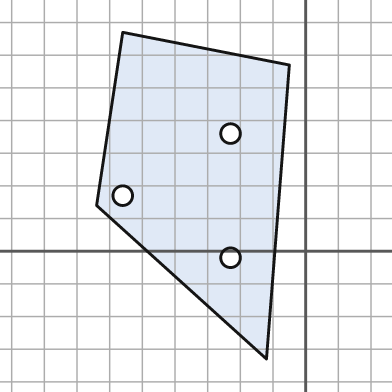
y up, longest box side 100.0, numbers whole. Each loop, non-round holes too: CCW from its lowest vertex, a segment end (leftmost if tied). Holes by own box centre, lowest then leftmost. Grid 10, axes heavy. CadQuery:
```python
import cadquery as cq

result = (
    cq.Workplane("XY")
    .moveTo(-12.0, -33.0)
    .lineTo(-5.0, 57.0)
    .lineTo(-56.0, 67.0)
    .lineTo(-64.0, 14.0)
    .close()
    .moveTo(-23.0, -2.0)
    .circle(3.0)
    .moveTo(-56.0, 17.0)
    .circle(3.0)
    .moveTo(-23.0, 36.0)
    .circle(3.0)
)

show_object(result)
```